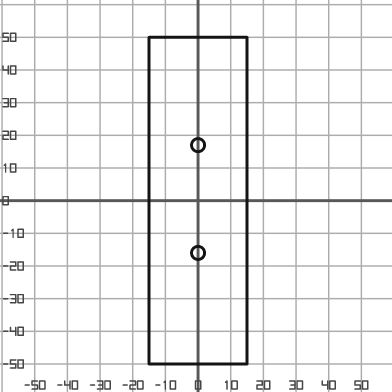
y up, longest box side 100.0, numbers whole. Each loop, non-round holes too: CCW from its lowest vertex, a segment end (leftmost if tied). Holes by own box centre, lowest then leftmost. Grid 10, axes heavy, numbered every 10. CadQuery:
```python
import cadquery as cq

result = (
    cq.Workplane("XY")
    .moveTo(-15.0, -50.0)
    .lineTo(15.0, -50.0)
    .lineTo(15.0, 50.0)
    .lineTo(-15.0, 50.0)
    .close()
    .moveTo(0.0, -16.0)
    .circle(2.0)
    .moveTo(0.0, 17.0)
    .circle(2.0)
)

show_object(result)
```